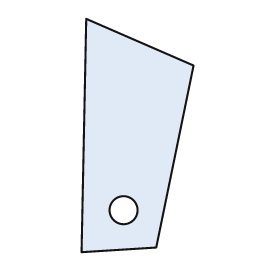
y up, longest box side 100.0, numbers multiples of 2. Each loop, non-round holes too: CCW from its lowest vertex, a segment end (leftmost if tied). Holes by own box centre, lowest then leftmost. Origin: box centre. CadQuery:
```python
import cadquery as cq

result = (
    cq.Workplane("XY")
    .moveTo(-24.0, -50.0)
    .lineTo(8.0, -48.0)
    .lineTo(24.0, 30.0)
    .lineTo(-22.0, 50.0)
    .close()
    .moveTo(-6.0, -32.0)
    .circle(6.0)
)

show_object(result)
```